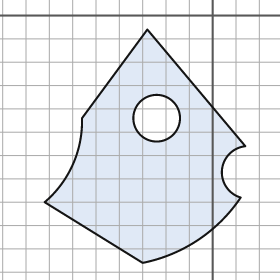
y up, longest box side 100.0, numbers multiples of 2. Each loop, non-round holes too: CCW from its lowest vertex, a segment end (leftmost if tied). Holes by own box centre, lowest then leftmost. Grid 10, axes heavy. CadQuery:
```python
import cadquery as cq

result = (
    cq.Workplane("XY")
    .moveTo(-30.0, -106.0)
    .threePointArc((-6.0, -96.0), (12.0, -78.0))
    .threePointArc((4.0, -66.0), (14.0, -56.0))
    .lineTo(-28.0, -6.0)
    .lineTo(-56.0, -44.0)
    .threePointArc((-60.0, -64.0), (-72.0, -80.0))
    .close()
    .moveTo(-24.0, -44.0)
    .circle(10.0)
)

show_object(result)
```